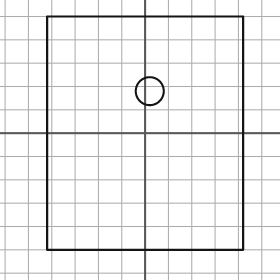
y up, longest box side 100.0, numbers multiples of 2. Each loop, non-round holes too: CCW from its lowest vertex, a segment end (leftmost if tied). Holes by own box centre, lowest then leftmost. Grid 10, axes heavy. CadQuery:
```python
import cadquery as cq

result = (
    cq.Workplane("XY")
    .moveTo(-42.0, -50.0)
    .lineTo(42.0, -50.0)
    .lineTo(42.0, 50.0)
    .lineTo(-42.0, 50.0)
    .close()
    .moveTo(2.0, 18.0)
    .circle(6.0)
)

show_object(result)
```